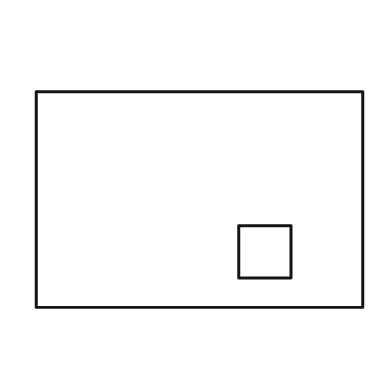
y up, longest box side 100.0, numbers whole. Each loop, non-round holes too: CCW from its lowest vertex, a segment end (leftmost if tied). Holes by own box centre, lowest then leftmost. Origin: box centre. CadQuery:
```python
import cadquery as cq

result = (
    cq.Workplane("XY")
    .moveTo(-50.0, -33.0)
    .lineTo(50.0, -33.0)
    .lineTo(50.0, 33.0)
    .lineTo(-50.0, 33.0)
    .close()
    .moveTo(12.0, -24.0)
    .lineTo(28.0, -24.0)
    .lineTo(28.0, -8.0)
    .lineTo(12.0, -8.0)
    .close()
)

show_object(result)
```